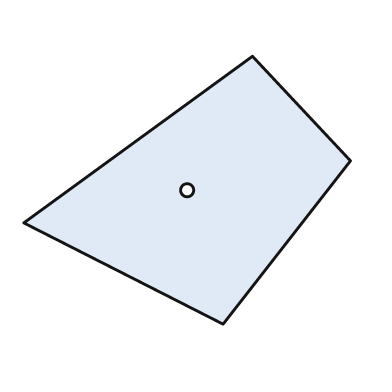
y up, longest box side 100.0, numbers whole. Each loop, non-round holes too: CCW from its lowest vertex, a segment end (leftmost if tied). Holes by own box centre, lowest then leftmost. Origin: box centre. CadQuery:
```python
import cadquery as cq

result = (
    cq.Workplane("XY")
    .moveTo(11.0, -41.0)
    .lineTo(50.0, 9.0)
    .lineTo(20.0, 41.0)
    .lineTo(-50.0, -10.0)
    .close()
    .moveTo(0.0, 0.0)
    .circle(2.0)
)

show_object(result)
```